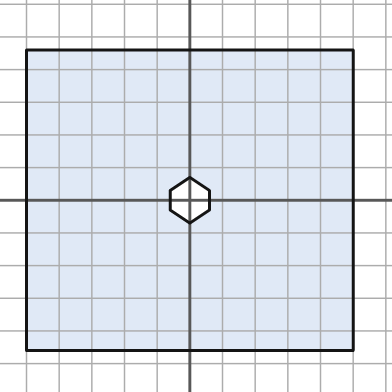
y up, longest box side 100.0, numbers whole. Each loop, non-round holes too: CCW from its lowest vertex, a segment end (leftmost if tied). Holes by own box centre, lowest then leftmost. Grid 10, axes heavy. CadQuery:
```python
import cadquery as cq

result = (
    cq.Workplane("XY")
    .moveTo(-50.0, -46.0)
    .lineTo(50.0, -46.0)
    .lineTo(50.0, 46.0)
    .lineTo(-50.0, 46.0)
    .close()
    .moveTo(0.0, -7.0)
    .lineTo(6.0, -3.0)
    .lineTo(6.0, 3.0)
    .lineTo(0.0, 7.0)
    .lineTo(-6.0, 3.0)
    .lineTo(-6.0, -3.0)
    .close()
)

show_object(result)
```